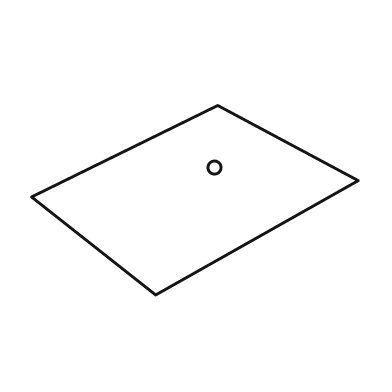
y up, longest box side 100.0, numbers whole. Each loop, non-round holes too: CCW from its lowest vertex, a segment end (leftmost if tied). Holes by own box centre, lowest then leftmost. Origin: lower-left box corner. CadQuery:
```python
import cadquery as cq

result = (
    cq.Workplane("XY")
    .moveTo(38.0, 0.0)
    .lineTo(100.0, 35.0)
    .lineTo(57.0, 58.0)
    .lineTo(0.0, 30.0)
    .close()
    .moveTo(56.0, 39.0)
    .circle(2.0)
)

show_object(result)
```